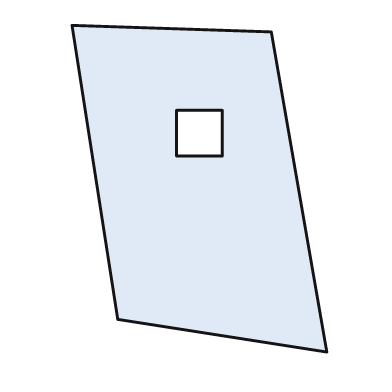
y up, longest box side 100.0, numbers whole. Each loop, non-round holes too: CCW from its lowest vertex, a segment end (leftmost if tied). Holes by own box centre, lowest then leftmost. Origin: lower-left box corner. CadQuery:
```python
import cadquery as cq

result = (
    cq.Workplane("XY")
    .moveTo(78.0, 0.0)
    .lineTo(61.0, 98.0)
    .lineTo(0.0, 100.0)
    .lineTo(14.0, 10.0)
    .close()
    .moveTo(32.0, 60.0)
    .lineTo(46.0, 60.0)
    .lineTo(46.0, 74.0)
    .lineTo(32.0, 74.0)
    .close()
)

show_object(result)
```